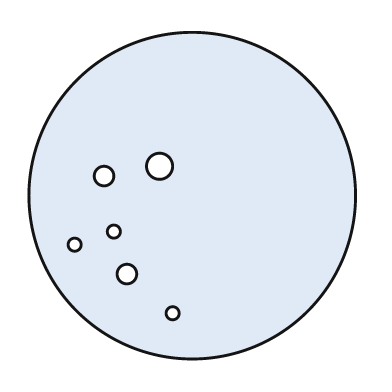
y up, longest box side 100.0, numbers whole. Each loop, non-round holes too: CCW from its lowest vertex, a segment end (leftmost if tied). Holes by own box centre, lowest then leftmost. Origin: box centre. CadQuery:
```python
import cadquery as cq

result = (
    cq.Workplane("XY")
    .moveTo(0.0, 0.0)
    .circle(50.0)
    .moveTo(-6.0, -36.0)
    .circle(2.0)
    .moveTo(-20.0, -24.0)
    .circle(3.0)
    .moveTo(-36.0, -15.0)
    .circle(2.0)
    .moveTo(-24.0, -11.0)
    .circle(2.0)
    .moveTo(-27.0, 6.0)
    .circle(3.0)
    .moveTo(-10.0, 9.0)
    .circle(4.0)
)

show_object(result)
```